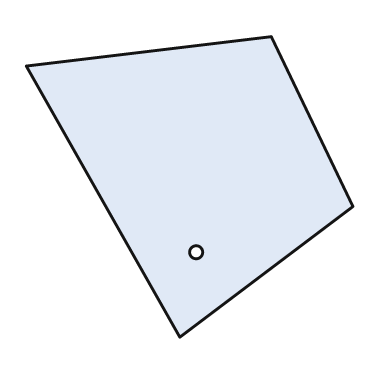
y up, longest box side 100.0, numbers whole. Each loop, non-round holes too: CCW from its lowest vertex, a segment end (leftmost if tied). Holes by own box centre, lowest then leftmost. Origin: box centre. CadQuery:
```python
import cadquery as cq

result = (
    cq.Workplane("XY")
    .moveTo(-3.0, -46.0)
    .lineTo(50.0, -6.0)
    .lineTo(25.0, 46.0)
    .lineTo(-50.0, 37.0)
    .close()
    .moveTo(2.0, -20.0)
    .circle(2.0)
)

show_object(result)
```